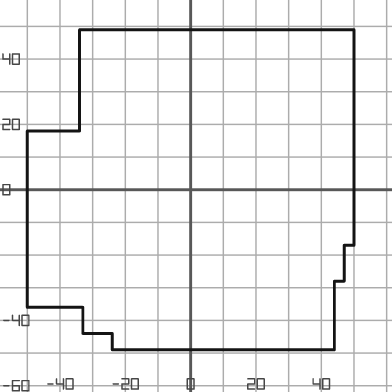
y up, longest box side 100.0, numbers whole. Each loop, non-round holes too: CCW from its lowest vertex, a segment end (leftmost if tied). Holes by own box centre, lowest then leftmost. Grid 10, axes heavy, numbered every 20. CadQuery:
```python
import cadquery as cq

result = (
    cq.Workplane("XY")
    .moveTo(-24.0, -49.0)
    .lineTo(44.0, -49.0)
    .lineTo(44.0, -28.0)
    .lineTo(47.0, -28.0)
    .lineTo(47.0, -17.0)
    .lineTo(50.0, -17.0)
    .lineTo(50.0, 49.0)
    .lineTo(-34.0, 49.0)
    .lineTo(-34.0, 18.0)
    .lineTo(-50.0, 18.0)
    .lineTo(-50.0, -36.0)
    .lineTo(-33.0, -36.0)
    .lineTo(-33.0, -44.0)
    .lineTo(-24.0, -44.0)
    .close()
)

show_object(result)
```